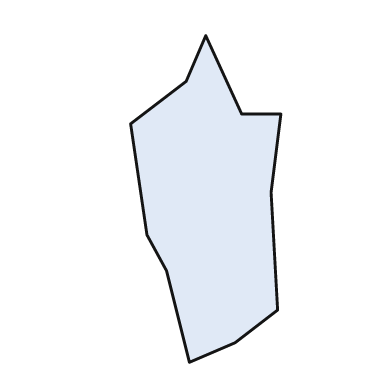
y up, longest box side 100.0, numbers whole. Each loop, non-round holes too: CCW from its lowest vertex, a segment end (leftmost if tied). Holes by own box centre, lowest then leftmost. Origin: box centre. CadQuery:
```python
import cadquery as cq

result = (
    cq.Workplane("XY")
    .moveTo(-5.0, -50.0)
    .lineTo(9.0, -44.0)
    .lineTo(22.0, -34.0)
    .lineTo(20.0, 2.0)
    .lineTo(23.0, 26.0)
    .lineTo(11.0, 26.0)
    .lineTo(0.0, 50.0)
    .lineTo(-6.0, 36.0)
    .lineTo(-23.0, 23.0)
    .lineTo(-18.0, -11.0)
    .lineTo(-12.0, -22.0)
    .close()
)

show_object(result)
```